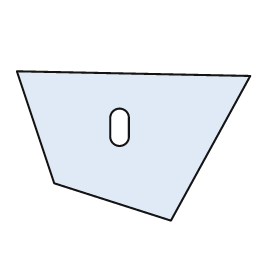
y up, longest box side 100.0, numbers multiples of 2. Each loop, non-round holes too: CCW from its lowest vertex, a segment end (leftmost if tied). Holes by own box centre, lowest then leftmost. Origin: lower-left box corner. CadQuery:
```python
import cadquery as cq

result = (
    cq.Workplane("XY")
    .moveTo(66.0, 0.0)
    .lineTo(100.0, 62.0)
    .lineTo(0.0, 64.0)
    .lineTo(16.0, 16.0)
    .close()
    .moveTo(40.0, 36.0)
    .threePointArc((44.0, 32.0), (48.0, 36.0))
    .lineTo(48.0, 44.0)
    .threePointArc((44.0, 48.0), (40.0, 44.0))
    .close()
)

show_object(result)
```